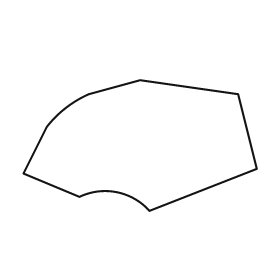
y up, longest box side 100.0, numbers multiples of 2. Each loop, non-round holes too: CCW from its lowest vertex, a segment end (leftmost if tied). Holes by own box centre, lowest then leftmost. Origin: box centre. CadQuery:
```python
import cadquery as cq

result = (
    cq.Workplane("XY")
    .moveTo(4.0, -28.0)
    .lineTo(50.0, -10.0)
    .lineTo(42.0, 22.0)
    .lineTo(0.0, 28.0)
    .lineTo(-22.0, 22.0)
    .threePointArc((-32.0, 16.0), (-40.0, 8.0))
    .lineTo(-50.0, -12.0)
    .lineTo(-26.0, -22.0)
    .threePointArc((-10.0, -20.0), (4.0, -28.0))
    .close()
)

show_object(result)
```